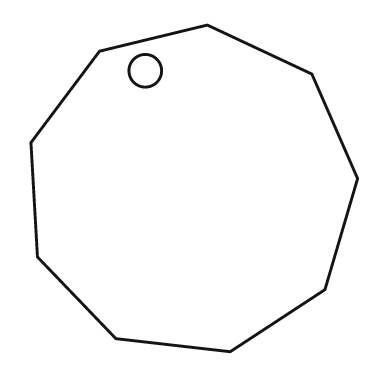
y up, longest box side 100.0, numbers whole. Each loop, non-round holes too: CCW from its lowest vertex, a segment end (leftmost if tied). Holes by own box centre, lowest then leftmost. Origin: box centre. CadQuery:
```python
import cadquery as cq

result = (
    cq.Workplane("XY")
    .moveTo(11.0, -50.0)
    .lineTo(40.0, -31.0)
    .lineTo(50.0, 3.0)
    .lineTo(36.0, 35.0)
    .lineTo(4.0, 50.0)
    .lineTo(-29.0, 42.0)
    .lineTo(-50.0, 14.0)
    .lineTo(-48.0, -21.0)
    .lineTo(-24.0, -46.0)
    .close()
    .moveTo(-15.0, 36.0)
    .circle(5.0)
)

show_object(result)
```